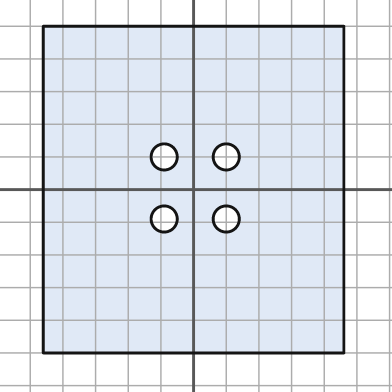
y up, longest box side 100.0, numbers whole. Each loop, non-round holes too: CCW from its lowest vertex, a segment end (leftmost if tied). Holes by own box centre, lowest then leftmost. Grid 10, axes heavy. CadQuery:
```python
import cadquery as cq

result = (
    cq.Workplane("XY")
    .moveTo(-46.0, -50.0)
    .lineTo(46.0, -50.0)
    .lineTo(46.0, 50.0)
    .lineTo(-46.0, 50.0)
    .close()
    .moveTo(-9.0, -9.0)
    .circle(4.0)
    .moveTo(10.0, -9.0)
    .circle(4.0)
    .moveTo(-9.0, 10.0)
    .circle(4.0)
    .moveTo(10.0, 10.0)
    .circle(4.0)
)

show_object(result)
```